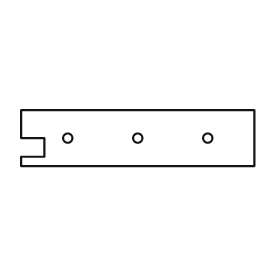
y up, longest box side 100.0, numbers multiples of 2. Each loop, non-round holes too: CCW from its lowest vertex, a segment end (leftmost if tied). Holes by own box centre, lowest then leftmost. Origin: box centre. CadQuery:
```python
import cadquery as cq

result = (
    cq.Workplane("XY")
    .moveTo(-50.0, -12.0)
    .lineTo(50.0, -12.0)
    .lineTo(50.0, 12.0)
    .lineTo(-50.0, 12.0)
    .lineTo(-50.0, 0.0)
    .lineTo(-40.0, 0.0)
    .lineTo(-40.0, -8.0)
    .lineTo(-50.0, -8.0)
    .close()
    .moveTo(-30.0, 0.0)
    .circle(2.0)
    .moveTo(0.0, 0.0)
    .circle(2.0)
    .moveTo(30.0, 0.0)
    .circle(2.0)
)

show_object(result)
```